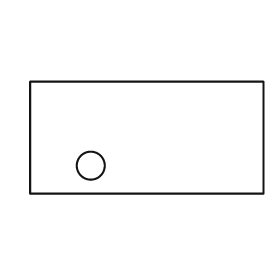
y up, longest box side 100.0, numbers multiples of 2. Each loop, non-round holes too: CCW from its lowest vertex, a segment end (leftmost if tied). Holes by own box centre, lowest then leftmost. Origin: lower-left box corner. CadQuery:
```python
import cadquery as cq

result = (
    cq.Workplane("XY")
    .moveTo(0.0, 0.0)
    .lineTo(100.0, 0.0)
    .lineTo(100.0, 48.0)
    .lineTo(0.0, 48.0)
    .close()
    .moveTo(26.0, 12.0)
    .circle(6.0)
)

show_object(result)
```